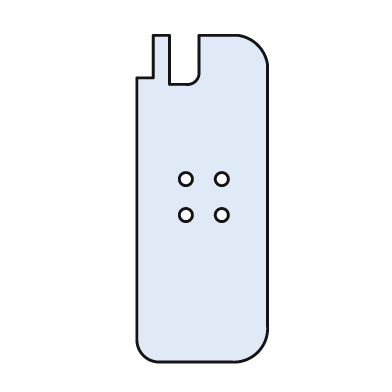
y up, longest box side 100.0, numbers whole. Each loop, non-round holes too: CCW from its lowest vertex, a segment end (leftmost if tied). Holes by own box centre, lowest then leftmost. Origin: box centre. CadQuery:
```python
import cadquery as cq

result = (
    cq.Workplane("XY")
    .moveTo(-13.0, -50.0)
    .lineTo(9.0, -50.0)
    .threePointArc((17.0, -47.0), (20.0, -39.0))
    .lineTo(20.0, 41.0)
    .threePointArc((17.0, 47.0), (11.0, 50.0))
    .lineTo(-1.0, 50.0)
    .lineTo(-1.0, 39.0)
    .threePointArc((-2.0, 36.0), (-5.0, 35.0))
    .lineTo(-10.0, 35.0)
    .lineTo(-10.0, 50.0)
    .lineTo(-15.0, 50.0)
    .lineTo(-15.0, 37.0)
    .lineTo(-20.0, 37.0)
    .lineTo(-20.0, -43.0)
    .threePointArc((-18.0, -48.0), (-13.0, -50.0))
    .close()
    .moveTo(-5.0, -5.0)
    .circle(2.0)
    .moveTo(6.0, -5.0)
    .circle(2.0)
    .moveTo(-5.0, 6.0)
    .circle(2.0)
    .moveTo(6.0, 6.0)
    .circle(2.0)
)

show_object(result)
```